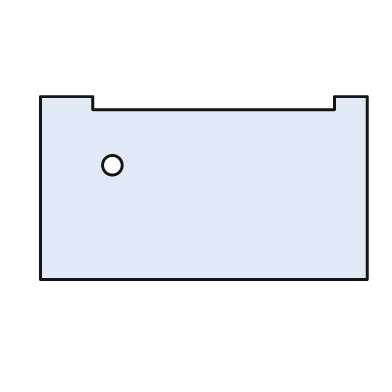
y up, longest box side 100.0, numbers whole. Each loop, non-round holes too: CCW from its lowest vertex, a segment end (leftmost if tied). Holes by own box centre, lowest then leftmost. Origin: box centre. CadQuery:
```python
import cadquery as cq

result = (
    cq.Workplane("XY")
    .moveTo(-50.0, -28.0)
    .lineTo(50.0, -28.0)
    .lineTo(50.0, 28.0)
    .lineTo(40.0, 28.0)
    .lineTo(40.0, 24.0)
    .lineTo(-34.0, 24.0)
    .lineTo(-34.0, 28.0)
    .lineTo(-50.0, 28.0)
    .close()
    .moveTo(-28.0, 7.0)
    .circle(3.0)
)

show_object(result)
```